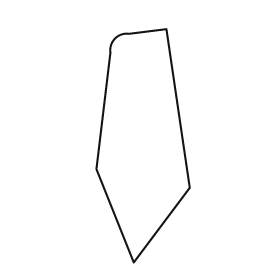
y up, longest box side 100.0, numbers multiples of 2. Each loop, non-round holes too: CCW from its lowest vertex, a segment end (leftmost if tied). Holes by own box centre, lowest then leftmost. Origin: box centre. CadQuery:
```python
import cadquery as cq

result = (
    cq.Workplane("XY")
    .moveTo(-4.0, -50.0)
    .lineTo(20.0, -18.0)
    .lineTo(10.0, 50.0)
    .lineTo(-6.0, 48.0)
    .threePointArc((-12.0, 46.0), (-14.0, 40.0))
    .lineTo(-20.0, -10.0)
    .close()
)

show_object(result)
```